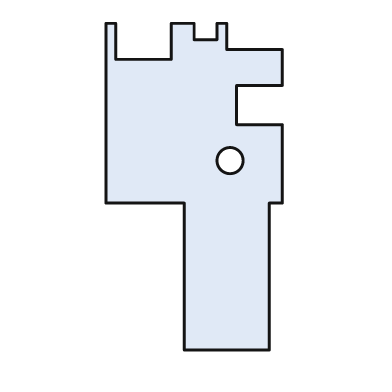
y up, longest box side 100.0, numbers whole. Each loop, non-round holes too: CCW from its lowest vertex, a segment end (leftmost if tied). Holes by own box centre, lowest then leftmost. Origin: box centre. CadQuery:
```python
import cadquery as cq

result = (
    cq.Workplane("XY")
    .moveTo(-3.0, -50.0)
    .lineTo(23.0, -50.0)
    .lineTo(23.0, -5.0)
    .lineTo(27.0, -5.0)
    .lineTo(27.0, 19.0)
    .lineTo(13.0, 19.0)
    .lineTo(13.0, 31.0)
    .lineTo(27.0, 31.0)
    .lineTo(27.0, 42.0)
    .lineTo(10.0, 42.0)
    .lineTo(10.0, 50.0)
    .lineTo(7.0, 50.0)
    .lineTo(7.0, 45.0)
    .lineTo(0.0, 45.0)
    .lineTo(0.0, 50.0)
    .lineTo(-7.0, 50.0)
    .lineTo(-7.0, 39.0)
    .lineTo(-24.0, 39.0)
    .lineTo(-24.0, 50.0)
    .lineTo(-27.0, 50.0)
    .lineTo(-27.0, -5.0)
    .lineTo(-3.0, -5.0)
    .close()
    .moveTo(11.0, 8.0)
    .circle(4.0)
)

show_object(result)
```